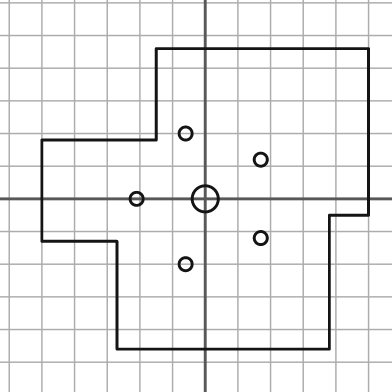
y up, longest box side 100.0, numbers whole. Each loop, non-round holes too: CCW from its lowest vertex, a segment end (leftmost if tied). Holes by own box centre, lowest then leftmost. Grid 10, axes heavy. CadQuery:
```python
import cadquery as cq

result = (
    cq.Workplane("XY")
    .moveTo(-27.0, -46.0)
    .lineTo(38.0, -46.0)
    .lineTo(38.0, -5.0)
    .lineTo(50.0, -5.0)
    .lineTo(50.0, 46.0)
    .lineTo(-15.0, 46.0)
    .lineTo(-15.0, 18.0)
    .lineTo(-50.0, 18.0)
    .lineTo(-50.0, -13.0)
    .lineTo(-27.0, -13.0)
    .close()
    .moveTo(-6.0, -20.0)
    .circle(2.0)
    .moveTo(17.0, -12.0)
    .circle(2.0)
    .moveTo(-21.0, 0.0)
    .circle(2.0)
    .moveTo(0.0, 0.0)
    .circle(4.0)
    .moveTo(17.0, 12.0)
    .circle(2.0)
    .moveTo(-6.0, 20.0)
    .circle(2.0)
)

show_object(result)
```